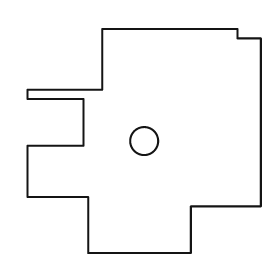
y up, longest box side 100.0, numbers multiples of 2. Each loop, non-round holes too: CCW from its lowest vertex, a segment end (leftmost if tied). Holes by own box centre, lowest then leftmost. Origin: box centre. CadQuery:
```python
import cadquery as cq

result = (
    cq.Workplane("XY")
    .moveTo(-24.0, -48.0)
    .lineTo(20.0, -48.0)
    .lineTo(20.0, -28.0)
    .lineTo(50.0, -28.0)
    .lineTo(50.0, 44.0)
    .lineTo(40.0, 44.0)
    .lineTo(40.0, 48.0)
    .lineTo(-18.0, 48.0)
    .lineTo(-18.0, 22.0)
    .lineTo(-50.0, 22.0)
    .lineTo(-50.0, 18.0)
    .lineTo(-26.0, 18.0)
    .lineTo(-26.0, -2.0)
    .lineTo(-50.0, -2.0)
    .lineTo(-50.0, -24.0)
    .lineTo(-24.0, -24.0)
    .close()
    .moveTo(0.0, 0.0)
    .circle(6.0)
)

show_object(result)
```